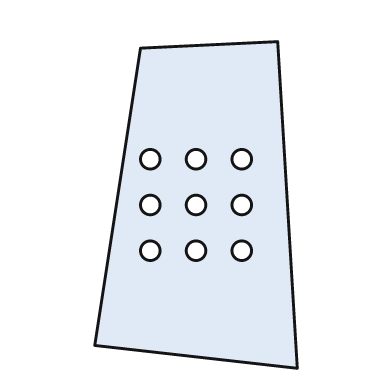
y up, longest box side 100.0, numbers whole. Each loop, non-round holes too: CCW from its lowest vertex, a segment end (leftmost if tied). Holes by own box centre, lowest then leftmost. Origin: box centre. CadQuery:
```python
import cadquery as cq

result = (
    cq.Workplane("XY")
    .moveTo(31.0, -50.0)
    .lineTo(25.0, 50.0)
    .lineTo(-17.0, 48.0)
    .lineTo(-31.0, -43.0)
    .close()
    .moveTo(-14.0, -14.0)
    .circle(3.0)
    .moveTo(0.0, -14.0)
    .circle(3.0)
    .moveTo(14.0, -14.0)
    .circle(3.0)
    .moveTo(-14.0, 0.0)
    .circle(3.0)
    .moveTo(0.0, 0.0)
    .circle(3.0)
    .moveTo(14.0, 0.0)
    .circle(3.0)
    .moveTo(-14.0, 14.0)
    .circle(3.0)
    .moveTo(0.0, 14.0)
    .circle(3.0)
    .moveTo(14.0, 14.0)
    .circle(3.0)
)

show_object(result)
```